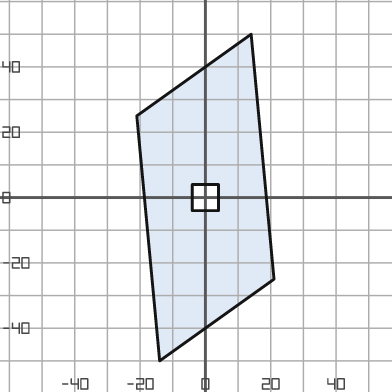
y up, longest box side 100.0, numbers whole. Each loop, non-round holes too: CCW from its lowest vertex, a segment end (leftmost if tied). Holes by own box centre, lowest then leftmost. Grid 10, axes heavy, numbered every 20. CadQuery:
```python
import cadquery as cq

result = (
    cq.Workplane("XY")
    .moveTo(-14.0, -50.0)
    .lineTo(21.0, -25.0)
    .lineTo(14.0, 50.0)
    .lineTo(-21.0, 25.0)
    .close()
    .moveTo(-4.0, -4.0)
    .lineTo(4.0, -4.0)
    .lineTo(4.0, 4.0)
    .lineTo(-4.0, 4.0)
    .close()
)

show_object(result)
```